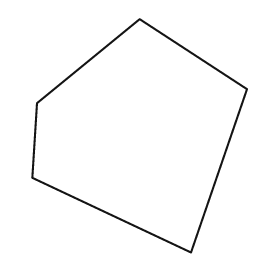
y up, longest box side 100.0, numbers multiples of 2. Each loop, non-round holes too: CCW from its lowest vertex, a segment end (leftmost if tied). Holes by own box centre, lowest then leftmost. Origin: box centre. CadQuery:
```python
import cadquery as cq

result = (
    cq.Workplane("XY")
    .moveTo(22.0, -50.0)
    .lineTo(46.0, 20.0)
    .lineTo(0.0, 50.0)
    .lineTo(-44.0, 14.0)
    .lineTo(-46.0, -18.0)
    .close()
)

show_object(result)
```